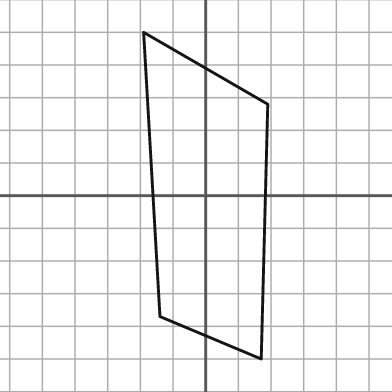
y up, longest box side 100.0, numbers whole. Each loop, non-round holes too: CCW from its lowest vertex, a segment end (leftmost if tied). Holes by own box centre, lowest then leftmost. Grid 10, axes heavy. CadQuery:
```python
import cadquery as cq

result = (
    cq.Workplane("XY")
    .moveTo(17.0, -50.0)
    .lineTo(19.0, 28.0)
    .lineTo(-19.0, 50.0)
    .lineTo(-14.0, -37.0)
    .close()
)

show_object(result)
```